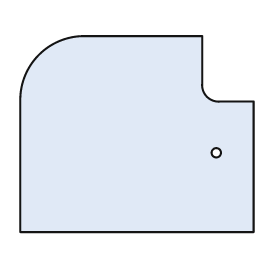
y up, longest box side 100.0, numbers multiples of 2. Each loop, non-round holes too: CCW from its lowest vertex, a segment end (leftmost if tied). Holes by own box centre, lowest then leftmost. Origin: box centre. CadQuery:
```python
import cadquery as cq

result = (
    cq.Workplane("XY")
    .moveTo(-50.0, -42.0)
    .lineTo(50.0, -42.0)
    .lineTo(50.0, 14.0)
    .lineTo(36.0, 14.0)
    .threePointArc((30.0, 16.0), (28.0, 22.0))
    .lineTo(28.0, 42.0)
    .lineTo(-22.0, 42.0)
    .threePointArc((-42.0, 34.0), (-50.0, 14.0))
    .close()
    .moveTo(34.0, -8.0)
    .circle(2.0)
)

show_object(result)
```